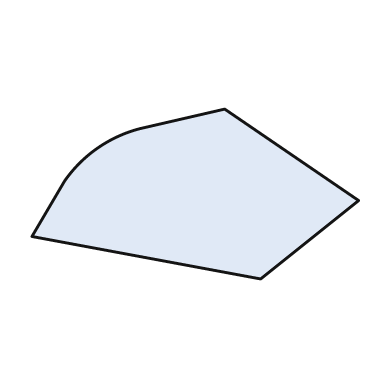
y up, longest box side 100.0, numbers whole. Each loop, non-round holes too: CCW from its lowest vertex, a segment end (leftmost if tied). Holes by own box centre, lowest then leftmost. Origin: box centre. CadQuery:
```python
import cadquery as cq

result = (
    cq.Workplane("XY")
    .moveTo(20.0, -26.0)
    .lineTo(50.0, -2.0)
    .lineTo(9.0, 26.0)
    .lineTo(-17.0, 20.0)
    .threePointArc((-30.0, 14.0), (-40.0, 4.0))
    .lineTo(-50.0, -13.0)
    .close()
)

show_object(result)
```